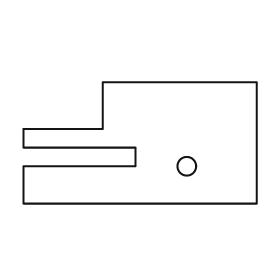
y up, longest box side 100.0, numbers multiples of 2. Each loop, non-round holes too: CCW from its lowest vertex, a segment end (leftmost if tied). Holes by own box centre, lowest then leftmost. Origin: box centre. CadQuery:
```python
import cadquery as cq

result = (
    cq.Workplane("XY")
    .moveTo(-50.0, -26.0)
    .lineTo(50.0, -26.0)
    .lineTo(50.0, 26.0)
    .lineTo(-16.0, 26.0)
    .lineTo(-16.0, 6.0)
    .lineTo(-50.0, 6.0)
    .lineTo(-50.0, -2.0)
    .lineTo(-2.0, -2.0)
    .lineTo(-2.0, -10.0)
    .lineTo(-50.0, -10.0)
    .close()
    .moveTo(20.0, -10.0)
    .circle(4.0)
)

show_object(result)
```